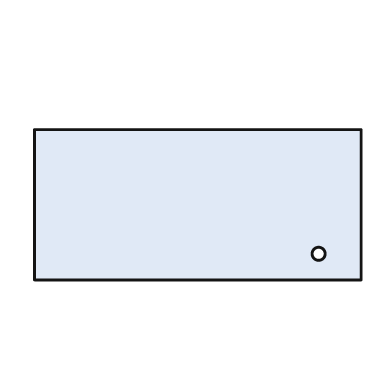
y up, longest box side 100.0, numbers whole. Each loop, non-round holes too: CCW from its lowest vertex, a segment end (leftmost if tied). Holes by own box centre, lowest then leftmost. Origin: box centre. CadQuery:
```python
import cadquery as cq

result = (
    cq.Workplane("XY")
    .moveTo(-50.0, -23.0)
    .lineTo(50.0, -23.0)
    .lineTo(50.0, 23.0)
    .lineTo(-50.0, 23.0)
    .close()
    .moveTo(37.0, -15.0)
    .circle(2.0)
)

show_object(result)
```